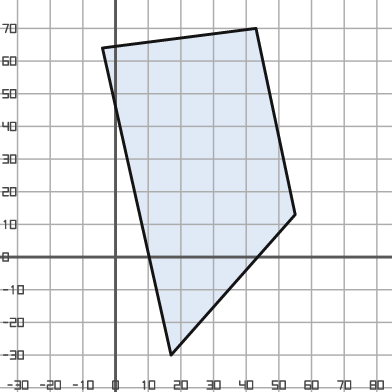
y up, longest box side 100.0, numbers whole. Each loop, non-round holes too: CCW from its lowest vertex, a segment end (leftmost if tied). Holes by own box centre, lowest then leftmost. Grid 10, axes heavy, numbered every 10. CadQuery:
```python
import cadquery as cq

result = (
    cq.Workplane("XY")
    .moveTo(17.0, -30.0)
    .lineTo(55.0, 13.0)
    .lineTo(43.0, 70.0)
    .lineTo(-4.0, 64.0)
    .close()
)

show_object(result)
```